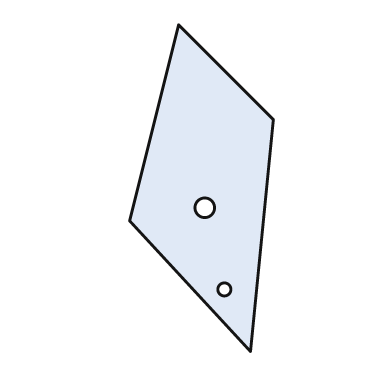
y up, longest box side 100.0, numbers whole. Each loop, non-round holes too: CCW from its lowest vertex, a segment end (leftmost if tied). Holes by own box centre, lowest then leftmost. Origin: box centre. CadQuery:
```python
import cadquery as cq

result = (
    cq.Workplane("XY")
    .moveTo(15.0, -50.0)
    .lineTo(22.0, 21.0)
    .lineTo(-7.0, 50.0)
    .lineTo(-22.0, -10.0)
    .close()
    .moveTo(7.0, -31.0)
    .circle(2.0)
    .moveTo(1.0, -6.0)
    .circle(3.0)
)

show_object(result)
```